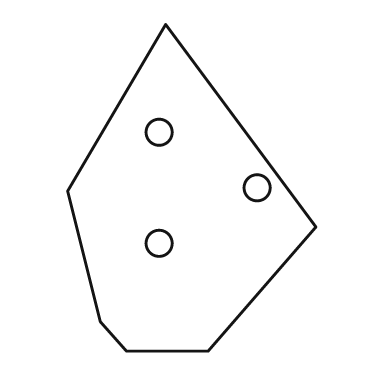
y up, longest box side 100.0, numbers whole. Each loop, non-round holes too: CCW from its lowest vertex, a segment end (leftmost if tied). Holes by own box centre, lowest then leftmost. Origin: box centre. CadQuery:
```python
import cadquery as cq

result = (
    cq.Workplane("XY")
    .moveTo(-20.0, -50.0)
    .lineTo(5.0, -50.0)
    .lineTo(38.0, -12.0)
    .lineTo(-8.0, 50.0)
    .lineTo(-38.0, -1.0)
    .lineTo(-28.0, -41.0)
    .close()
    .moveTo(-10.0, -17.0)
    .circle(4.0)
    .moveTo(20.0, 0.0)
    .circle(4.0)
    .moveTo(-10.0, 17.0)
    .circle(4.0)
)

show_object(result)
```